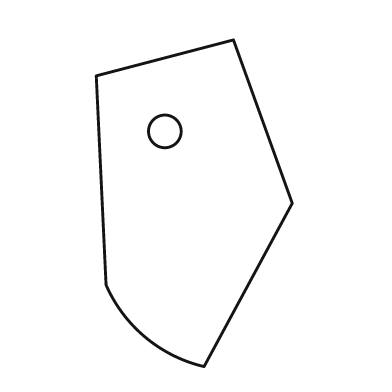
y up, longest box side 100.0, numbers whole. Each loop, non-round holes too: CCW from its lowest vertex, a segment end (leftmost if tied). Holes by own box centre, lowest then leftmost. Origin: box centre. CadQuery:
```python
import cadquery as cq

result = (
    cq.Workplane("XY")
    .moveTo(3.0, -50.0)
    .lineTo(30.0, 0.0)
    .lineTo(12.0, 50.0)
    .lineTo(-30.0, 39.0)
    .lineTo(-27.0, -25.0)
    .threePointArc((-15.0, -41.0), (3.0, -50.0))
    .close()
    .moveTo(-9.0, 22.0)
    .circle(5.0)
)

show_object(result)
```